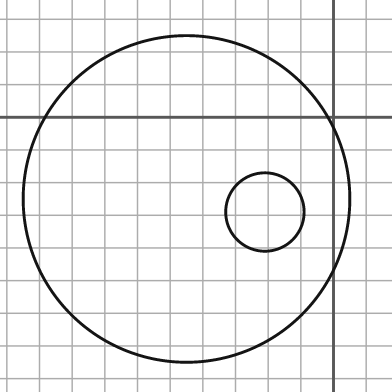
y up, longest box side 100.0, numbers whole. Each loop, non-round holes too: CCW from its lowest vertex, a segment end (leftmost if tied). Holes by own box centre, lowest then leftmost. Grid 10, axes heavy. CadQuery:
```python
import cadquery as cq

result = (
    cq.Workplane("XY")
    .moveTo(-45.0, -25.0)
    .circle(50.0)
    .moveTo(-21.0, -29.0)
    .circle(12.0)
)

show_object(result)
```